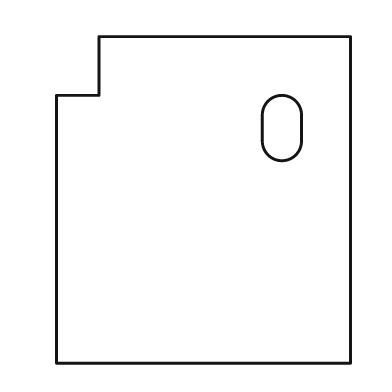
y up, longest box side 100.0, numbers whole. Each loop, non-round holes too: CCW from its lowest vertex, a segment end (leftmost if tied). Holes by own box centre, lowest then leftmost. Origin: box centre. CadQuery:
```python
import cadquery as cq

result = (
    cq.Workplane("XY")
    .moveTo(-45.0, -50.0)
    .lineTo(45.0, -50.0)
    .lineTo(45.0, 50.0)
    .lineTo(-32.0, 50.0)
    .lineTo(-32.0, 32.0)
    .lineTo(-45.0, 32.0)
    .close()
    .moveTo(18.0, 18.0)
    .threePointArc((24.0, 12.0), (30.0, 18.0))
    .lineTo(30.0, 26.0)
    .threePointArc((24.0, 32.0), (18.0, 26.0))
    .close()
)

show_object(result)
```